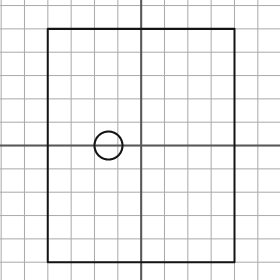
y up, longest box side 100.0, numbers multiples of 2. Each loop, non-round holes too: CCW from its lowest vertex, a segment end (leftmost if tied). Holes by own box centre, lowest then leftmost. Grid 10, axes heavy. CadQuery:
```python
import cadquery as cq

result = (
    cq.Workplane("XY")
    .moveTo(-40.0, -50.0)
    .lineTo(40.0, -50.0)
    .lineTo(40.0, 50.0)
    .lineTo(-40.0, 50.0)
    .close()
    .moveTo(-14.0, 0.0)
    .circle(6.0)
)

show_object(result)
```